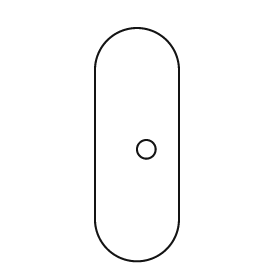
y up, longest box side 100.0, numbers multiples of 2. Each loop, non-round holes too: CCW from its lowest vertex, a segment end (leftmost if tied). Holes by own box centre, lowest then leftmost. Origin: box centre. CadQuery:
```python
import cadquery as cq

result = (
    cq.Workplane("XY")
    .moveTo(-18.0, -32.0)
    .threePointArc((0.0, -50.0), (18.0, -32.0))
    .lineTo(18.0, 32.0)
    .threePointArc((0.0, 50.0), (-18.0, 32.0))
    .close()
    .moveTo(4.0, -2.0)
    .circle(4.0)
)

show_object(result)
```